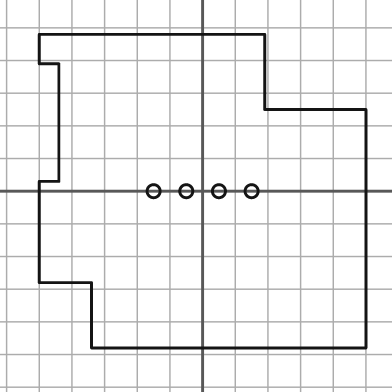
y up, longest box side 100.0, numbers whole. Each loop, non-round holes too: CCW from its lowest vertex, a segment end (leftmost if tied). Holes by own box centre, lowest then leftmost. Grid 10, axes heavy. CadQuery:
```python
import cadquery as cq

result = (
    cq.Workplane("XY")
    .moveTo(-34.0, -48.0)
    .lineTo(50.0, -48.0)
    .lineTo(50.0, 25.0)
    .lineTo(19.0, 25.0)
    .lineTo(19.0, 48.0)
    .lineTo(-50.0, 48.0)
    .lineTo(-50.0, 39.0)
    .lineTo(-44.0, 39.0)
    .lineTo(-44.0, 3.0)
    .lineTo(-50.0, 3.0)
    .lineTo(-50.0, -28.0)
    .lineTo(-34.0, -28.0)
    .close()
    .moveTo(-15.0, 0.0)
    .circle(2.0)
    .moveTo(-5.0, 0.0)
    .circle(2.0)
    .moveTo(5.0, 0.0)
    .circle(2.0)
    .moveTo(15.0, 0.0)
    .circle(2.0)
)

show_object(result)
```